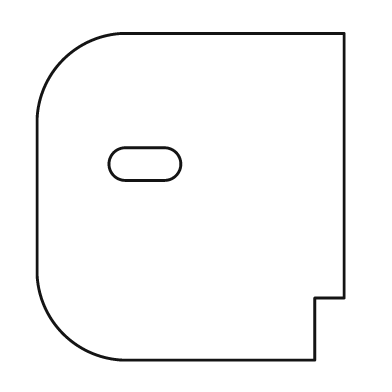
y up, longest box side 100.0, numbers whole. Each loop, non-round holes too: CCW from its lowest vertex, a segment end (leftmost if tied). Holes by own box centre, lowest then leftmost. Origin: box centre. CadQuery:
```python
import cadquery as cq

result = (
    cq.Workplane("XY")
    .moveTo(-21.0, -50.0)
    .lineTo(38.0, -50.0)
    .lineTo(38.0, -31.0)
    .lineTo(47.0, -31.0)
    .lineTo(47.0, 50.0)
    .lineTo(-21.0, 50.0)
    .threePointArc((-39.0, 42.0), (-47.0, 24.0))
    .lineTo(-47.0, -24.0)
    .threePointArc((-39.0, -42.0), (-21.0, -50.0))
    .close()
    .moveTo(-20.0, 5.0)
    .lineTo(-8.0, 5.0)
    .threePointArc((-3.0, 10.0), (-8.0, 15.0))
    .lineTo(-20.0, 15.0)
    .threePointArc((-25.0, 10.0), (-20.0, 5.0))
    .close()
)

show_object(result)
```